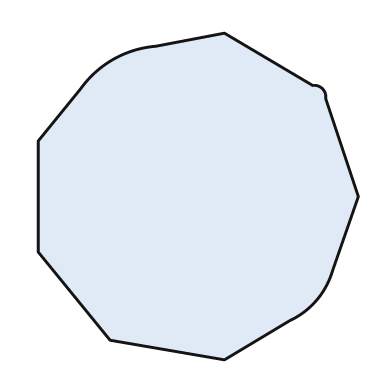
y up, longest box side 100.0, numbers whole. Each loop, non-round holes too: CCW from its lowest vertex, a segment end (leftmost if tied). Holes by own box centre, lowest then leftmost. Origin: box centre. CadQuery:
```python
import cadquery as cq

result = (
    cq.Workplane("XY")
    .moveTo(8.0, -50.0)
    .lineTo(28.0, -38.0)
    .threePointArc((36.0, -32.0), (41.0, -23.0))
    .lineTo(49.0, 0.0)
    .lineTo(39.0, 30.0)
    .threePointArc((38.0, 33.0), (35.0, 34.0))
    .lineTo(8.0, 50.0)
    .lineTo(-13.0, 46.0)
    .threePointArc((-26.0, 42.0), (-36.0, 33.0))
    .lineTo(-49.0, 17.0)
    .lineTo(-49.0, -17.0)
    .lineTo(-27.0, -44.0)
    .close()
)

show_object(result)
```